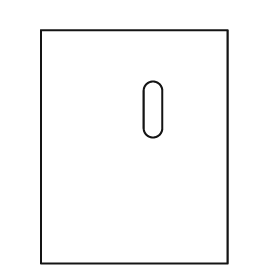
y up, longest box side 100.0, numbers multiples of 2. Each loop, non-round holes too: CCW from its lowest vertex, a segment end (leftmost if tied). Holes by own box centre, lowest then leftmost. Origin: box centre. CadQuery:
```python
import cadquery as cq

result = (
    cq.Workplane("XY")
    .moveTo(-40.0, -50.0)
    .lineTo(40.0, -50.0)
    .lineTo(40.0, 50.0)
    .lineTo(-40.0, 50.0)
    .close()
    .moveTo(4.0, 8.0)
    .threePointArc((8.0, 4.0), (12.0, 8.0))
    .lineTo(12.0, 24.0)
    .threePointArc((8.0, 28.0), (4.0, 24.0))
    .close()
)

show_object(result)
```